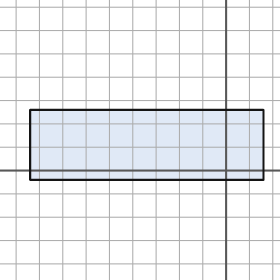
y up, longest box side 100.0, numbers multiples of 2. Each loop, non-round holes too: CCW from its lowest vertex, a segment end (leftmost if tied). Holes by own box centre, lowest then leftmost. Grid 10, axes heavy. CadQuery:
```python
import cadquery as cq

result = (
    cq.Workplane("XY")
    .moveTo(-84.0, -4.0)
    .lineTo(16.0, -4.0)
    .lineTo(16.0, 26.0)
    .lineTo(-84.0, 26.0)
    .close()
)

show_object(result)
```